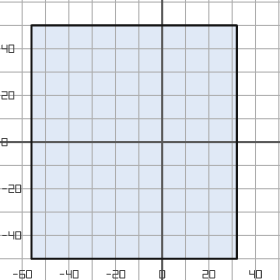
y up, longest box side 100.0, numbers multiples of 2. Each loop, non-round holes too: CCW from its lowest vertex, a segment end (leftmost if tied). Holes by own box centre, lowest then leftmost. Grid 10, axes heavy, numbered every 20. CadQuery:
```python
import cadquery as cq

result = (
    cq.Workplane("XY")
    .moveTo(-56.0, -50.0)
    .lineTo(32.0, -50.0)
    .lineTo(32.0, 50.0)
    .lineTo(-56.0, 50.0)
    .close()
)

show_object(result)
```